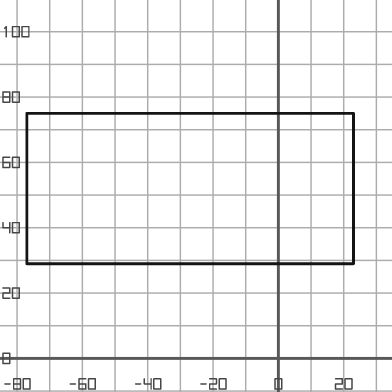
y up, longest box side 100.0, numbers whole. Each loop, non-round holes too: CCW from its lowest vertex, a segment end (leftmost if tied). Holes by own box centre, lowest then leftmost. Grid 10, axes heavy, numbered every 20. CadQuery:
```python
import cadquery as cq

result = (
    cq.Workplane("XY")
    .moveTo(-77.0, 29.0)
    .lineTo(23.0, 29.0)
    .lineTo(23.0, 75.0)
    .lineTo(-77.0, 75.0)
    .close()
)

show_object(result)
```